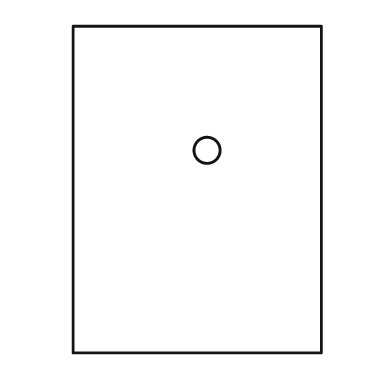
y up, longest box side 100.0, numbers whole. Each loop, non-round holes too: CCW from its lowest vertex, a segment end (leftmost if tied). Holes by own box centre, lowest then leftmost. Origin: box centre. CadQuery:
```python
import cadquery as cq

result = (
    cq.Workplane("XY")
    .moveTo(-38.0, -50.0)
    .lineTo(38.0, -50.0)
    .lineTo(38.0, 50.0)
    .lineTo(-38.0, 50.0)
    .close()
    .moveTo(3.0, 12.0)
    .circle(4.0)
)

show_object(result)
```